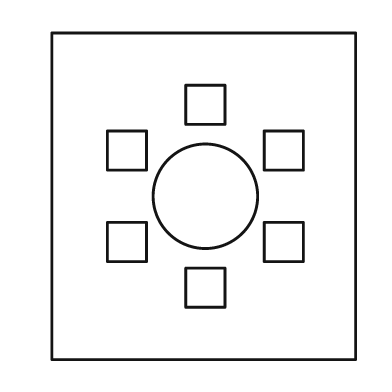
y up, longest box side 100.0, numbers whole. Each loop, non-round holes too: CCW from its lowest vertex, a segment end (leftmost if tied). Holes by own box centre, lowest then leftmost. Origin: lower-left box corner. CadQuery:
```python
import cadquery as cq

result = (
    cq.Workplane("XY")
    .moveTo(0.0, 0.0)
    .lineTo(93.0, 0.0)
    .lineTo(93.0, 100.0)
    .lineTo(0.0, 100.0)
    .close()
    .moveTo(41.0, 16.0)
    .lineTo(53.0, 16.0)
    .lineTo(53.0, 28.0)
    .lineTo(41.0, 28.0)
    .close()
    .moveTo(17.0, 30.0)
    .lineTo(29.0, 30.0)
    .lineTo(29.0, 42.0)
    .lineTo(17.0, 42.0)
    .close()
    .moveTo(65.0, 30.0)
    .lineTo(77.0, 30.0)
    .lineTo(77.0, 42.0)
    .lineTo(65.0, 42.0)
    .close()
    .moveTo(47.0, 50.0)
    .circle(16.0)
    .moveTo(17.0, 58.0)
    .lineTo(29.0, 58.0)
    .lineTo(29.0, 70.0)
    .lineTo(17.0, 70.0)
    .close()
    .moveTo(65.0, 58.0)
    .lineTo(77.0, 58.0)
    .lineTo(77.0, 70.0)
    .lineTo(65.0, 70.0)
    .close()
    .moveTo(41.0, 72.0)
    .lineTo(53.0, 72.0)
    .lineTo(53.0, 84.0)
    .lineTo(41.0, 84.0)
    .close()
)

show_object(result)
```